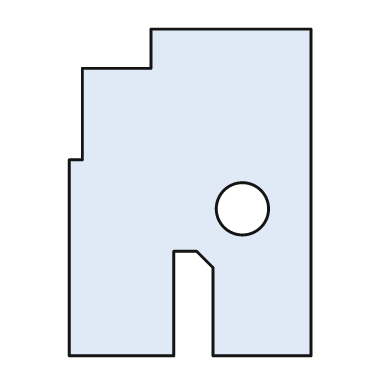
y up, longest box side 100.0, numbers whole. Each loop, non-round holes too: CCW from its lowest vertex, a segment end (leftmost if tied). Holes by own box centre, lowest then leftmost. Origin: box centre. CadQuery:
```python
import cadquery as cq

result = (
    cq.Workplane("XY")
    .moveTo(-37.0, -50.0)
    .lineTo(-5.0, -50.0)
    .lineTo(-5.0, -18.0)
    .lineTo(2.0, -18.0)
    .lineTo(7.0, -23.0)
    .lineTo(7.0, -50.0)
    .lineTo(37.0, -50.0)
    .lineTo(37.0, 50.0)
    .lineTo(-12.0, 50.0)
    .lineTo(-12.0, 38.0)
    .lineTo(-33.0, 38.0)
    .lineTo(-33.0, 10.0)
    .lineTo(-37.0, 10.0)
    .close()
    .moveTo(16.0, -5.0)
    .circle(8.0)
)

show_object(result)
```